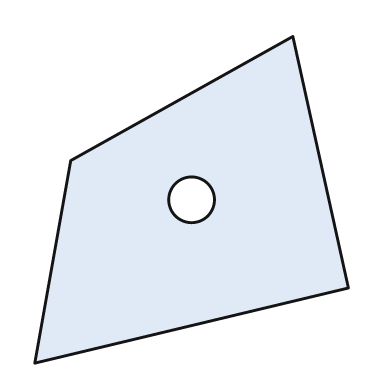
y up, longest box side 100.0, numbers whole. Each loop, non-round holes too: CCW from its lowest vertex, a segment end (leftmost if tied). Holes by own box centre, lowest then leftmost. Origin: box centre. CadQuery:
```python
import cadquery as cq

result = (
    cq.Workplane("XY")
    .moveTo(-48.0, -50.0)
    .lineTo(48.0, -27.0)
    .lineTo(31.0, 50.0)
    .lineTo(-37.0, 12.0)
    .close()
    .moveTo(0.0, 0.0)
    .circle(7.0)
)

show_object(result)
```